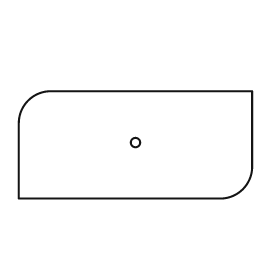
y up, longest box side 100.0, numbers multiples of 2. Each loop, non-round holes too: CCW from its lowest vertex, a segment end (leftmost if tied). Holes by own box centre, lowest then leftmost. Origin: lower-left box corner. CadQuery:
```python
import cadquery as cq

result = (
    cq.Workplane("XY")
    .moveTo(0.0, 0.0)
    .lineTo(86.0, 0.0)
    .threePointArc((96.0, 4.0), (100.0, 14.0))
    .lineTo(100.0, 46.0)
    .lineTo(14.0, 46.0)
    .threePointArc((4.0, 42.0), (0.0, 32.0))
    .close()
    .moveTo(50.0, 24.0)
    .circle(2.0)
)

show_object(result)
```